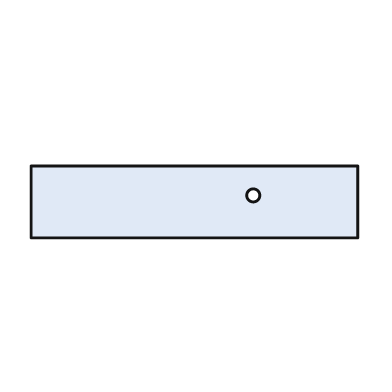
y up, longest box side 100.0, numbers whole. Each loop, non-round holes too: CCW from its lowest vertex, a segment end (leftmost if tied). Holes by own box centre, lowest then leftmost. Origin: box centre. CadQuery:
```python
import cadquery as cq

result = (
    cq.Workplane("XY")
    .moveTo(-50.0, -11.0)
    .lineTo(50.0, -11.0)
    .lineTo(50.0, 11.0)
    .lineTo(-50.0, 11.0)
    .close()
    .moveTo(18.0, 2.0)
    .circle(2.0)
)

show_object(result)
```